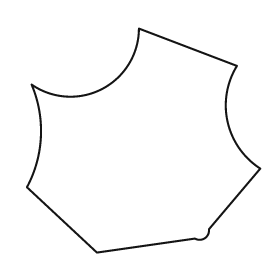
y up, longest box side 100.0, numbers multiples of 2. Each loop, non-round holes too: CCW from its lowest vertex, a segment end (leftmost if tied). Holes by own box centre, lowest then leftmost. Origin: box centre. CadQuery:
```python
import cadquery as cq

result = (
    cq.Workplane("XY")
    .moveTo(-20.0, -48.0)
    .lineTo(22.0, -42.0)
    .threePointArc((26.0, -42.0), (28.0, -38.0))
    .lineTo(50.0, -12.0)
    .threePointArc((36.0, 8.0), (40.0, 32.0))
    .lineTo(-2.0, 48.0)
    .threePointArc((-18.0, 22.0), (-48.0, 24.0))
    .threePointArc((-44.0, 2.0), (-50.0, -20.0))
    .close()
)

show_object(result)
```